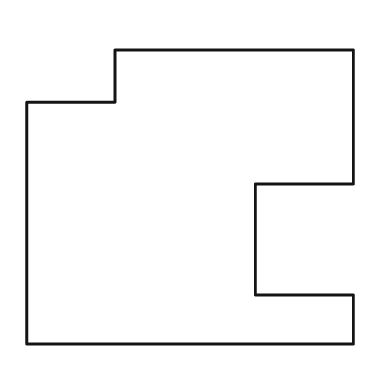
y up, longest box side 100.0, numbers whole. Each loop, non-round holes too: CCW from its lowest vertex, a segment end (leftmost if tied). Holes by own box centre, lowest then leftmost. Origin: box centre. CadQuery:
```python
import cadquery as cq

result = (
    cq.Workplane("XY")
    .moveTo(-50.0, -45.0)
    .lineTo(50.0, -45.0)
    .lineTo(50.0, -30.0)
    .lineTo(20.0, -30.0)
    .lineTo(20.0, 4.0)
    .lineTo(50.0, 4.0)
    .lineTo(50.0, 45.0)
    .lineTo(-23.0, 45.0)
    .lineTo(-23.0, 29.0)
    .lineTo(-50.0, 29.0)
    .close()
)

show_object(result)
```